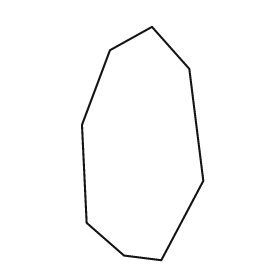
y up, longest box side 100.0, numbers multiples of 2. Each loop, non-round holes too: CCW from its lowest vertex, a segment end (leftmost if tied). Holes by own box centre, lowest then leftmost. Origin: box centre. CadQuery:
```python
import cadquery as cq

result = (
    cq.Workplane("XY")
    .moveTo(8.0, -50.0)
    .lineTo(26.0, -16.0)
    .lineTo(20.0, 32.0)
    .lineTo(4.0, 50.0)
    .lineTo(-14.0, 40.0)
    .lineTo(-26.0, 8.0)
    .lineTo(-24.0, -34.0)
    .lineTo(-8.0, -48.0)
    .close()
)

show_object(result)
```